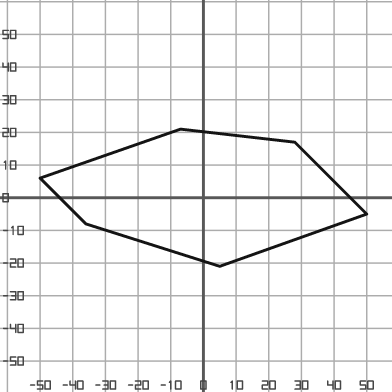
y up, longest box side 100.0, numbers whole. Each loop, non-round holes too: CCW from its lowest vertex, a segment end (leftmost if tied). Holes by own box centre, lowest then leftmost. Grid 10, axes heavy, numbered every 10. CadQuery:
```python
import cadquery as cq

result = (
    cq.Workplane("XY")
    .moveTo(5.0, -21.0)
    .lineTo(50.0, -5.0)
    .lineTo(28.0, 17.0)
    .lineTo(-7.0, 21.0)
    .lineTo(-50.0, 6.0)
    .lineTo(-36.0, -8.0)
    .close()
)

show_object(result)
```